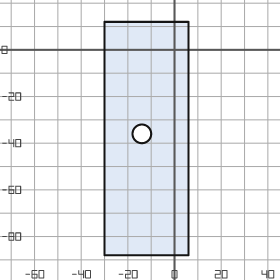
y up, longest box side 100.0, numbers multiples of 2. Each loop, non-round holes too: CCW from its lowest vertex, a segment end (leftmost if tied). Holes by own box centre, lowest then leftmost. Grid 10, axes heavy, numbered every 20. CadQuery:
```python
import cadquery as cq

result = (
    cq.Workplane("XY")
    .moveTo(-30.0, -88.0)
    .lineTo(6.0, -88.0)
    .lineTo(6.0, 12.0)
    .lineTo(-30.0, 12.0)
    .close()
    .moveTo(-14.0, -36.0)
    .circle(4.0)
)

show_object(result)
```